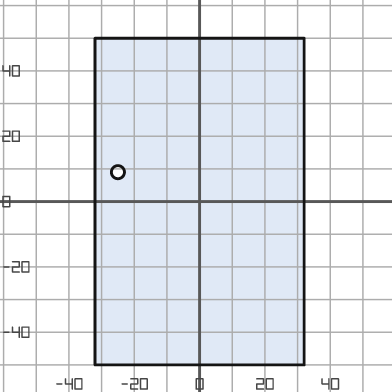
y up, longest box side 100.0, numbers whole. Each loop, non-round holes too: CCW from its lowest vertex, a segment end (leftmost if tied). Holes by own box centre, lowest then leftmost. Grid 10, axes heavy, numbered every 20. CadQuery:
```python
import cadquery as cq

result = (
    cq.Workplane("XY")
    .moveTo(-32.0, -50.0)
    .lineTo(32.0, -50.0)
    .lineTo(32.0, 50.0)
    .lineTo(-32.0, 50.0)
    .close()
    .moveTo(-25.0, 9.0)
    .circle(2.0)
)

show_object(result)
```